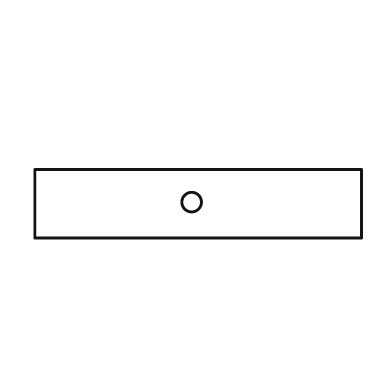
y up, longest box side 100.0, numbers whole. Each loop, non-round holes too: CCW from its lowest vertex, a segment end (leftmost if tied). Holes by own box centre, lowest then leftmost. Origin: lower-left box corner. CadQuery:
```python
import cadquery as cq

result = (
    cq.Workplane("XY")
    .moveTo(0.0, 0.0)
    .lineTo(100.0, 0.0)
    .lineTo(100.0, 21.0)
    .lineTo(0.0, 21.0)
    .close()
    .moveTo(48.0, 11.0)
    .circle(3.0)
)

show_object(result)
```